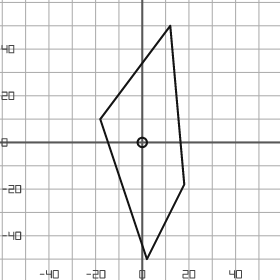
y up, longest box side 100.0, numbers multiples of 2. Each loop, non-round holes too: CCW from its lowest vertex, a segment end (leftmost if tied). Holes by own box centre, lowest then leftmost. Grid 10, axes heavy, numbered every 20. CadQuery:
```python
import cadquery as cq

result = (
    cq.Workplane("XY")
    .moveTo(2.0, -50.0)
    .lineTo(18.0, -18.0)
    .lineTo(12.0, 50.0)
    .lineTo(-18.0, 10.0)
    .close()
    .moveTo(0.0, 0.0)
    .circle(2.0)
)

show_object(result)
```